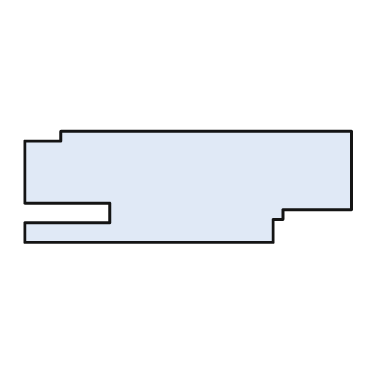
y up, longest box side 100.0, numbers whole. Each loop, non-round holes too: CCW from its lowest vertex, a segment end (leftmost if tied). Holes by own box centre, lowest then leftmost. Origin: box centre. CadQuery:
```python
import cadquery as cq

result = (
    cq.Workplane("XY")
    .moveTo(-50.0, -17.0)
    .lineTo(26.0, -17.0)
    .lineTo(26.0, -10.0)
    .lineTo(29.0, -10.0)
    .lineTo(29.0, -7.0)
    .lineTo(50.0, -7.0)
    .lineTo(50.0, 17.0)
    .lineTo(-39.0, 17.0)
    .lineTo(-39.0, 14.0)
    .lineTo(-50.0, 14.0)
    .lineTo(-50.0, -5.0)
    .lineTo(-24.0, -5.0)
    .lineTo(-24.0, -11.0)
    .lineTo(-50.0, -11.0)
    .close()
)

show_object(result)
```